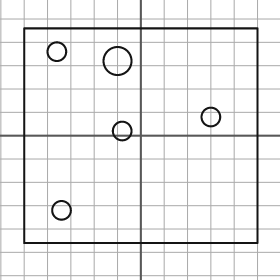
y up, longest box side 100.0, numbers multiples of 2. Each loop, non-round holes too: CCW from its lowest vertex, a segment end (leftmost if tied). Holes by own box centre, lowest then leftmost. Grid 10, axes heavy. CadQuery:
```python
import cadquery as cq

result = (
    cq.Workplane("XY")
    .moveTo(-50.0, -46.0)
    .lineTo(50.0, -46.0)
    .lineTo(50.0, 46.0)
    .lineTo(-50.0, 46.0)
    .close()
    .moveTo(-34.0, -32.0)
    .circle(4.0)
    .moveTo(-8.0, 2.0)
    .circle(4.0)
    .moveTo(30.0, 8.0)
    .circle(4.0)
    .moveTo(-10.0, 32.0)
    .circle(6.0)
    .moveTo(-36.0, 36.0)
    .circle(4.0)
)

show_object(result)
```